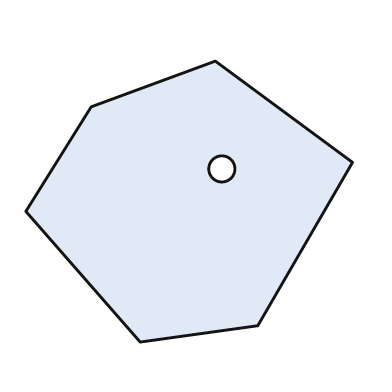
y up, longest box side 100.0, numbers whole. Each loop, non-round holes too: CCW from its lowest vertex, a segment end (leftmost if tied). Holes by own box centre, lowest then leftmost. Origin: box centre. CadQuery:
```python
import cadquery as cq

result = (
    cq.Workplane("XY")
    .moveTo(-15.0, -43.0)
    .lineTo(21.0, -38.0)
    .lineTo(50.0, 12.0)
    .lineTo(8.0, 43.0)
    .lineTo(-30.0, 29.0)
    .lineTo(-50.0, -3.0)
    .close()
    .moveTo(10.0, 10.0)
    .circle(4.0)
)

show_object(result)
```